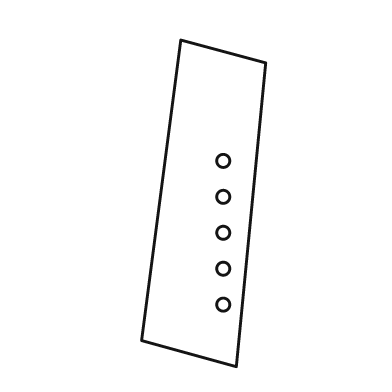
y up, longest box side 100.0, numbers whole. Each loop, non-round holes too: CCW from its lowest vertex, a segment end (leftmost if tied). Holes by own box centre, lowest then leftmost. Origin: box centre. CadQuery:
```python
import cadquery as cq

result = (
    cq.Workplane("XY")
    .moveTo(10.0, -50.0)
    .lineTo(19.0, 43.0)
    .lineTo(-7.0, 50.0)
    .lineTo(-19.0, -42.0)
    .close()
    .moveTo(6.0, -31.0)
    .circle(2.0)
    .moveTo(6.0, -20.0)
    .circle(2.0)
    .moveTo(6.0, -9.0)
    .circle(2.0)
    .moveTo(6.0, 2.0)
    .circle(2.0)
    .moveTo(6.0, 13.0)
    .circle(2.0)
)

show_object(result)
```